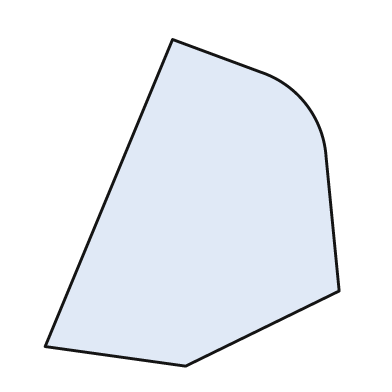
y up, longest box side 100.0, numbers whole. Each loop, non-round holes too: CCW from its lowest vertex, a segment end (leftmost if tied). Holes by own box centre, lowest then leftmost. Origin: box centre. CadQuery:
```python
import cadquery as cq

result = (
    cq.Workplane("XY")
    .moveTo(-2.0, -50.0)
    .lineTo(45.0, -27.0)
    .lineTo(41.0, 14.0)
    .threePointArc((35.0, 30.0), (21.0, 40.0))
    .lineTo(-6.0, 50.0)
    .lineTo(-45.0, -44.0)
    .close()
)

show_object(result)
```